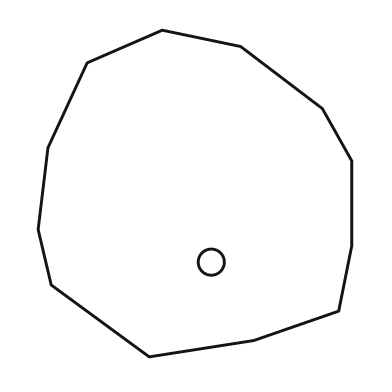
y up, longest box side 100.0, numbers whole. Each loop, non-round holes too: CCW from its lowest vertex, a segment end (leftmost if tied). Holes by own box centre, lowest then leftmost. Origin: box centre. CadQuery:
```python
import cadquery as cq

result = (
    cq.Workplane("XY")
    .moveTo(-14.0, -50.0)
    .lineTo(18.0, -45.0)
    .lineTo(44.0, -36.0)
    .lineTo(48.0, -16.0)
    .lineTo(48.0, 10.0)
    .lineTo(39.0, 26.0)
    .lineTo(14.0, 45.0)
    .lineTo(-10.0, 50.0)
    .lineTo(-33.0, 40.0)
    .lineTo(-45.0, 14.0)
    .lineTo(-48.0, -11.0)
    .lineTo(-44.0, -28.0)
    .close()
    .moveTo(5.0, -21.0)
    .circle(4.0)
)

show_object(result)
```